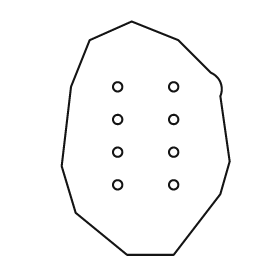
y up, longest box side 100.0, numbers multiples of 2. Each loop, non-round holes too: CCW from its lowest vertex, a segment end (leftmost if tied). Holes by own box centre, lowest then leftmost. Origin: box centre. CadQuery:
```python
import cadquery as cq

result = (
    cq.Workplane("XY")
    .moveTo(-8.0, -50.0)
    .lineTo(12.0, -50.0)
    .lineTo(32.0, -24.0)
    .lineTo(36.0, -10.0)
    .lineTo(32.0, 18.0)
    .threePointArc((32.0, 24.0), (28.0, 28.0))
    .lineTo(14.0, 42.0)
    .lineTo(-6.0, 50.0)
    .lineTo(-24.0, 42.0)
    .lineTo(-32.0, 22.0)
    .lineTo(-36.0, -12.0)
    .lineTo(-30.0, -32.0)
    .close()
    .moveTo(-12.0, -20.0)
    .circle(2.0)
    .moveTo(12.0, -20.0)
    .circle(2.0)
    .moveTo(-12.0, -6.0)
    .circle(2.0)
    .moveTo(12.0, -6.0)
    .circle(2.0)
    .moveTo(-12.0, 8.0)
    .circle(2.0)
    .moveTo(12.0, 8.0)
    .circle(2.0)
    .moveTo(-12.0, 22.0)
    .circle(2.0)
    .moveTo(12.0, 22.0)
    .circle(2.0)
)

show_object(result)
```